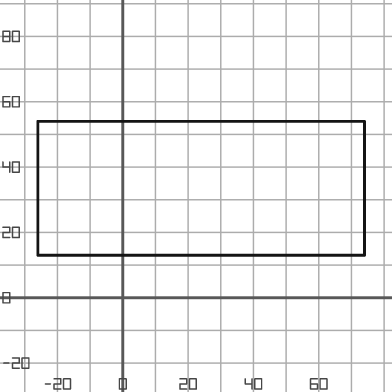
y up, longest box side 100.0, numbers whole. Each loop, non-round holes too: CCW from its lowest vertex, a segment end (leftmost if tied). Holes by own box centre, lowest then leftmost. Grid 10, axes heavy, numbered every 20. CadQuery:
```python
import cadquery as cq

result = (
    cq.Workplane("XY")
    .moveTo(-26.0, 13.0)
    .lineTo(74.0, 13.0)
    .lineTo(74.0, 54.0)
    .lineTo(-26.0, 54.0)
    .close()
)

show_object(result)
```